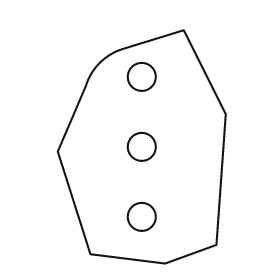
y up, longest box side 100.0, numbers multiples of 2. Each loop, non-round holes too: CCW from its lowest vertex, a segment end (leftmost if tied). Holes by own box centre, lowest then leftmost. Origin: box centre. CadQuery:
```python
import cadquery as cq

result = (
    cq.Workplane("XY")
    .moveTo(10.0, -50.0)
    .lineTo(32.0, -42.0)
    .lineTo(36.0, 14.0)
    .lineTo(18.0, 50.0)
    .lineTo(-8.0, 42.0)
    .threePointArc((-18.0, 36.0), (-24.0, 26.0))
    .lineTo(-36.0, -2.0)
    .lineTo(-22.0, -46.0)
    .close()
    .moveTo(0.0, -30.0)
    .circle(6.0)
    .moveTo(0.0, 0.0)
    .circle(6.0)
    .moveTo(0.0, 30.0)
    .circle(6.0)
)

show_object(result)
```